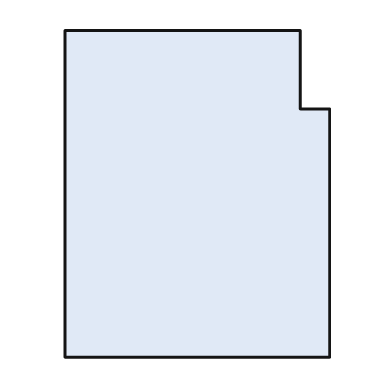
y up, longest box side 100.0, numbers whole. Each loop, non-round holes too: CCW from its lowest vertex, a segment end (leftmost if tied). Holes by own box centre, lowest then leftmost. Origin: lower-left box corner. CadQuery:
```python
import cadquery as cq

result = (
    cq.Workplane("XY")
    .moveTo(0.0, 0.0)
    .lineTo(81.0, 0.0)
    .lineTo(81.0, 76.0)
    .lineTo(72.0, 76.0)
    .lineTo(72.0, 100.0)
    .lineTo(0.0, 100.0)
    .close()
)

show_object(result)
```